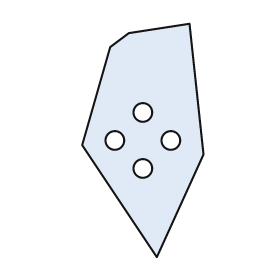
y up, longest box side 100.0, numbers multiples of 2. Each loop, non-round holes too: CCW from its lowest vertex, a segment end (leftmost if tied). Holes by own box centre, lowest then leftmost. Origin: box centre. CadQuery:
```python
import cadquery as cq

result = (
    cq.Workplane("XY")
    .moveTo(6.0, -50.0)
    .lineTo(26.0, -6.0)
    .lineTo(20.0, 50.0)
    .lineTo(-6.0, 46.0)
    .lineTo(-14.0, 40.0)
    .lineTo(-26.0, -2.0)
    .close()
    .moveTo(0.0, -12.0)
    .circle(4.0)
    .moveTo(-12.0, 0.0)
    .circle(4.0)
    .moveTo(12.0, 0.0)
    .circle(4.0)
    .moveTo(0.0, 12.0)
    .circle(4.0)
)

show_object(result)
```